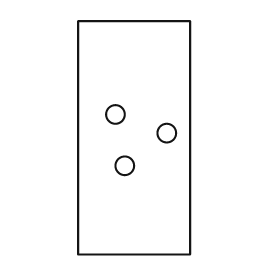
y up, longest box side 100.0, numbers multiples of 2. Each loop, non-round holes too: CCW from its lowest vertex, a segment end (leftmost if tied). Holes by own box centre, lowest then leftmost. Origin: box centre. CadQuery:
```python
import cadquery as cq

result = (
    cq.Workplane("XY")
    .moveTo(-24.0, -50.0)
    .lineTo(24.0, -50.0)
    .lineTo(24.0, 50.0)
    .lineTo(-24.0, 50.0)
    .close()
    .moveTo(-4.0, -12.0)
    .circle(4.0)
    .moveTo(14.0, 2.0)
    .circle(4.0)
    .moveTo(-8.0, 10.0)
    .circle(4.0)
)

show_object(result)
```